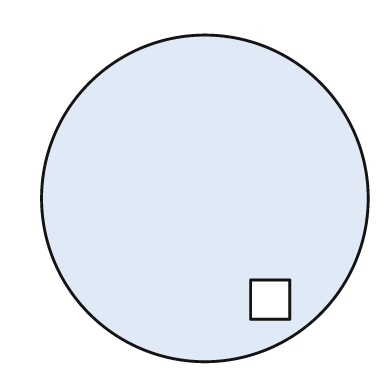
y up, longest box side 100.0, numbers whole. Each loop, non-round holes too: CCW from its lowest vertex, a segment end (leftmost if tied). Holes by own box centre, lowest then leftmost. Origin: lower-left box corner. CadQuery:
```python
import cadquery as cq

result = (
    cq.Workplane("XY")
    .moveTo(50.0, 50.0)
    .circle(50.0)
    .moveTo(64.0, 13.0)
    .lineTo(76.0, 13.0)
    .lineTo(76.0, 25.0)
    .lineTo(64.0, 25.0)
    .close()
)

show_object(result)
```